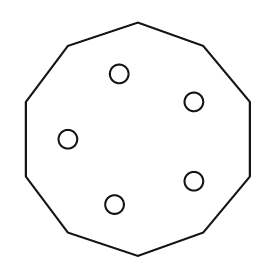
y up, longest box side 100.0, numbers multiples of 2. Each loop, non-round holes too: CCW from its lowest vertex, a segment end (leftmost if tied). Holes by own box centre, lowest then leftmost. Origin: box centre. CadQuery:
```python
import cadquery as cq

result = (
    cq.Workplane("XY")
    .moveTo(0.0, -50.0)
    .lineTo(28.0, -40.0)
    .lineTo(48.0, -16.0)
    .lineTo(48.0, 16.0)
    .lineTo(28.0, 40.0)
    .lineTo(0.0, 50.0)
    .lineTo(-30.0, 40.0)
    .lineTo(-48.0, 16.0)
    .lineTo(-48.0, -16.0)
    .lineTo(-30.0, -40.0)
    .close()
    .moveTo(-10.0, -28.0)
    .circle(4.0)
    .moveTo(24.0, -18.0)
    .circle(4.0)
    .moveTo(-30.0, 0.0)
    .circle(4.0)
    .moveTo(24.0, 16.0)
    .circle(4.0)
    .moveTo(-8.0, 28.0)
    .circle(4.0)
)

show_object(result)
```